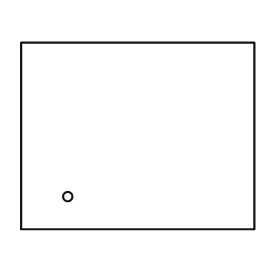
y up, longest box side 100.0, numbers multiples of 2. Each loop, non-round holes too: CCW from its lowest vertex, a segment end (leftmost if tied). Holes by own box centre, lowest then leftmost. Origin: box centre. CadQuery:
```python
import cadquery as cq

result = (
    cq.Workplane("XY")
    .moveTo(-50.0, -40.0)
    .lineTo(50.0, -40.0)
    .lineTo(50.0, 40.0)
    .lineTo(-50.0, 40.0)
    .close()
    .moveTo(-30.0, -26.0)
    .circle(2.0)
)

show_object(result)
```